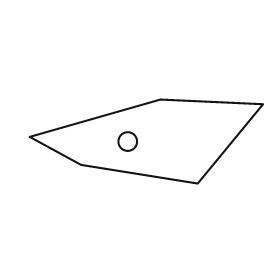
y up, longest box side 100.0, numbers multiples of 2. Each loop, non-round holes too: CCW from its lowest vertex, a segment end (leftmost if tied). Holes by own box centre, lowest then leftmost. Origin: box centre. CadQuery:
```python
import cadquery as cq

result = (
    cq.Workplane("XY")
    .moveTo(22.0, -18.0)
    .lineTo(50.0, 16.0)
    .lineTo(6.0, 18.0)
    .lineTo(-50.0, 2.0)
    .lineTo(-28.0, -10.0)
    .close()
    .moveTo(-8.0, 0.0)
    .circle(4.0)
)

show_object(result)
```